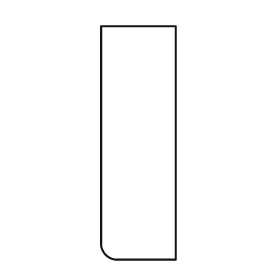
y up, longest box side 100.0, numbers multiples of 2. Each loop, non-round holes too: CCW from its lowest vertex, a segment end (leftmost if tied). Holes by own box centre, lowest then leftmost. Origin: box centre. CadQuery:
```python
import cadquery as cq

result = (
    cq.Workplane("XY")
    .moveTo(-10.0, -50.0)
    .lineTo(16.0, -50.0)
    .lineTo(16.0, 50.0)
    .lineTo(-16.0, 50.0)
    .lineTo(-16.0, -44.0)
    .threePointArc((-14.0, -48.0), (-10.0, -50.0))
    .close()
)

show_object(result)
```